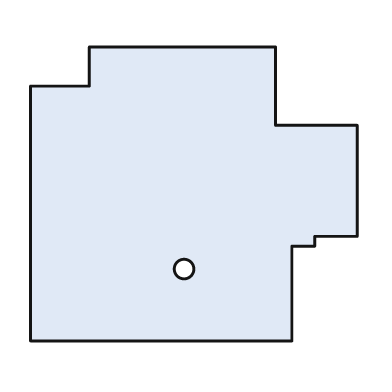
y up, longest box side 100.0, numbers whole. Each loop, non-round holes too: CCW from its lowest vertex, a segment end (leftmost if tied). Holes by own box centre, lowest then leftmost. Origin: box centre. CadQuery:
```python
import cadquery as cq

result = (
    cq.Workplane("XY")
    .moveTo(-50.0, -45.0)
    .lineTo(30.0, -45.0)
    .lineTo(30.0, -16.0)
    .lineTo(37.0, -16.0)
    .lineTo(37.0, -13.0)
    .lineTo(50.0, -13.0)
    .lineTo(50.0, 21.0)
    .lineTo(25.0, 21.0)
    .lineTo(25.0, 45.0)
    .lineTo(-32.0, 45.0)
    .lineTo(-32.0, 33.0)
    .lineTo(-50.0, 33.0)
    .close()
    .moveTo(-3.0, -23.0)
    .circle(3.0)
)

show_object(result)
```